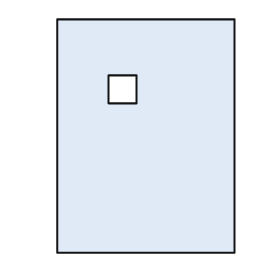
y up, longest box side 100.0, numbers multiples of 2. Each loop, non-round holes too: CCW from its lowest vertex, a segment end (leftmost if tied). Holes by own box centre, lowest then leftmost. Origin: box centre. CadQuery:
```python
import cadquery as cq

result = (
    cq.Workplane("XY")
    .moveTo(-38.0, -50.0)
    .lineTo(38.0, -50.0)
    .lineTo(38.0, 50.0)
    .lineTo(-38.0, 50.0)
    .close()
    .moveTo(-16.0, 14.0)
    .lineTo(-4.0, 14.0)
    .lineTo(-4.0, 26.0)
    .lineTo(-16.0, 26.0)
    .close()
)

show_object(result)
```